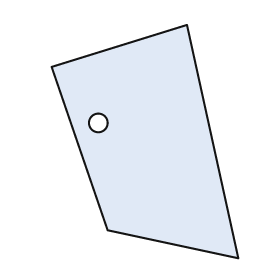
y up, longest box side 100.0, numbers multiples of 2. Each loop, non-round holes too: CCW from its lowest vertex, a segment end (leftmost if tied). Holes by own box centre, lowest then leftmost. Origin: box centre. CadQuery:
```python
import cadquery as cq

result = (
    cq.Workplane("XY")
    .moveTo(40.0, -50.0)
    .lineTo(18.0, 50.0)
    .lineTo(-40.0, 32.0)
    .lineTo(-16.0, -38.0)
    .close()
    .moveTo(-20.0, 8.0)
    .circle(4.0)
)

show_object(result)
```